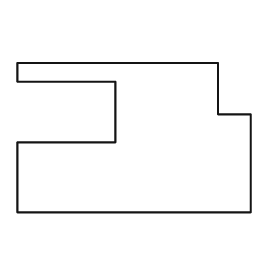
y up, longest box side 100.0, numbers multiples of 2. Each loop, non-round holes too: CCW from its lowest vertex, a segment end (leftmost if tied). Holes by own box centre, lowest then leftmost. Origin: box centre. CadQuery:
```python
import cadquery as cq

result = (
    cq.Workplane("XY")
    .moveTo(-50.0, -32.0)
    .lineTo(50.0, -32.0)
    .lineTo(50.0, 10.0)
    .lineTo(36.0, 10.0)
    .lineTo(36.0, 32.0)
    .lineTo(-50.0, 32.0)
    .lineTo(-50.0, 24.0)
    .lineTo(-8.0, 24.0)
    .lineTo(-8.0, -2.0)
    .lineTo(-50.0, -2.0)
    .close()
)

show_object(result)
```